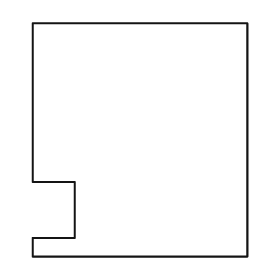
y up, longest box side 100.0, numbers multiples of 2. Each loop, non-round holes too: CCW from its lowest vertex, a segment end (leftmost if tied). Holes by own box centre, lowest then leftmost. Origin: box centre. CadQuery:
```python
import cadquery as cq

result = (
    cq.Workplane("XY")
    .moveTo(-46.0, -50.0)
    .lineTo(46.0, -50.0)
    .lineTo(46.0, 50.0)
    .lineTo(-46.0, 50.0)
    .lineTo(-46.0, -18.0)
    .lineTo(-28.0, -18.0)
    .lineTo(-28.0, -42.0)
    .lineTo(-46.0, -42.0)
    .close()
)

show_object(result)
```